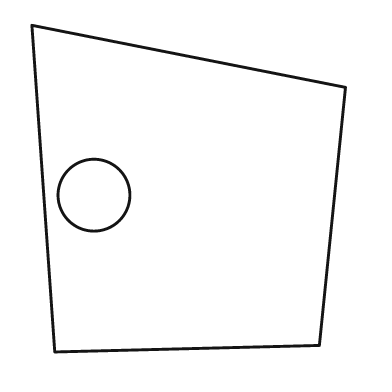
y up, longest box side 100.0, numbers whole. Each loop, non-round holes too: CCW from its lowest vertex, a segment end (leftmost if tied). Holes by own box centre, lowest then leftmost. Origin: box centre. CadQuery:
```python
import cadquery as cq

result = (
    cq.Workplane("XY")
    .moveTo(-41.0, -50.0)
    .lineTo(40.0, -48.0)
    .lineTo(48.0, 31.0)
    .lineTo(-48.0, 50.0)
    .close()
    .moveTo(-29.0, -2.0)
    .circle(11.0)
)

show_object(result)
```